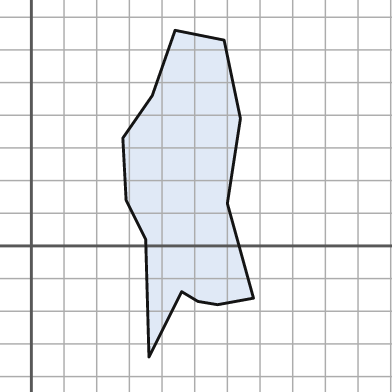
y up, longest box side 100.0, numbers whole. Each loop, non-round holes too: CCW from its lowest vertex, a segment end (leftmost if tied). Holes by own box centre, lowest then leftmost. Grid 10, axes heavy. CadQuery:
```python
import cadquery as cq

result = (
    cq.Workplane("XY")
    .moveTo(36.0, -34.0)
    .lineTo(46.0, -14.0)
    .lineTo(51.0, -17.0)
    .lineTo(57.0, -18.0)
    .lineTo(68.0, -16.0)
    .lineTo(60.0, 13.0)
    .lineTo(64.0, 39.0)
    .lineTo(59.0, 63.0)
    .lineTo(44.0, 66.0)
    .lineTo(37.0, 46.0)
    .lineTo(28.0, 33.0)
    .lineTo(29.0, 14.0)
    .lineTo(35.0, 2.0)
    .close()
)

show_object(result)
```